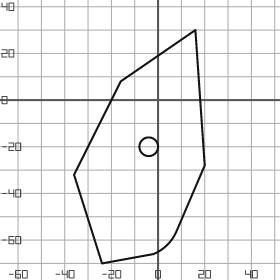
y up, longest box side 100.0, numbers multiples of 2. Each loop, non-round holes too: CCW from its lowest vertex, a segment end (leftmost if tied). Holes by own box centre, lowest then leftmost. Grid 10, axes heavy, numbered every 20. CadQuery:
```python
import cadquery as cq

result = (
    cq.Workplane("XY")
    .moveTo(-24.0, -70.0)
    .lineTo(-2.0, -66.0)
    .threePointArc((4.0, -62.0), (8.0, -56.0))
    .lineTo(20.0, -28.0)
    .lineTo(16.0, 30.0)
    .lineTo(-16.0, 8.0)
    .lineTo(-36.0, -32.0)
    .close()
    .moveTo(-4.0, -20.0)
    .circle(4.0)
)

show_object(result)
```